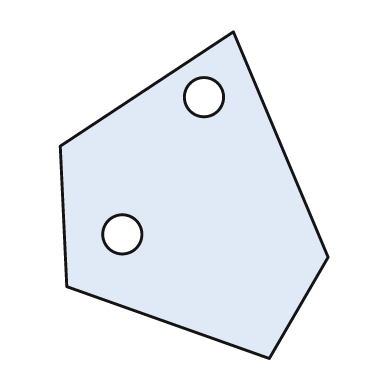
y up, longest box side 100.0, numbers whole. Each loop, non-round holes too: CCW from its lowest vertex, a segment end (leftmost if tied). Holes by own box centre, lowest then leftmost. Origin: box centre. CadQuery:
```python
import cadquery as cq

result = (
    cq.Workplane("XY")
    .moveTo(23.0, -50.0)
    .lineTo(41.0, -19.0)
    .lineTo(12.0, 50.0)
    .lineTo(-41.0, 15.0)
    .lineTo(-39.0, -28.0)
    .close()
    .moveTo(-22.0, -12.0)
    .circle(6.0)
    .moveTo(3.0, 30.0)
    .circle(6.0)
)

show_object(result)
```